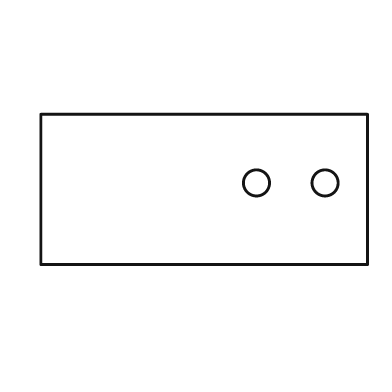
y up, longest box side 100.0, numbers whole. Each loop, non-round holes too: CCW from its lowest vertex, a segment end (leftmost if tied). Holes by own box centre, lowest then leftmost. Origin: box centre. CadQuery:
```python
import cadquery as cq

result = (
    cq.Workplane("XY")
    .moveTo(-50.0, -23.0)
    .lineTo(50.0, -23.0)
    .lineTo(50.0, 23.0)
    .lineTo(-50.0, 23.0)
    .close()
    .moveTo(16.0, 2.0)
    .circle(4.0)
    .moveTo(37.0, 2.0)
    .circle(4.0)
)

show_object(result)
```